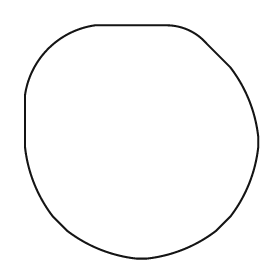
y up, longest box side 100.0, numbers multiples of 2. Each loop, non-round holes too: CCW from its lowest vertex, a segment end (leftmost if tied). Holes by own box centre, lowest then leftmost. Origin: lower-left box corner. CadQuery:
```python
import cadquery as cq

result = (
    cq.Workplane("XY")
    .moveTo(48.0, 0.0)
    .lineTo(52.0, 0.0)
    .threePointArc((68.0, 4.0), (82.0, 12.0))
    .lineTo(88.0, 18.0)
    .threePointArc((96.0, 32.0), (100.0, 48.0))
    .lineTo(100.0, 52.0)
    .threePointArc((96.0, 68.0), (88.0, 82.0))
    .lineTo(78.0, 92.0)
    .threePointArc((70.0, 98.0), (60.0, 100.0))
    .lineTo(30.0, 100.0)
    .threePointArc((10.0, 90.0), (0.0, 70.0))
    .lineTo(0.0, 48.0)
    .threePointArc((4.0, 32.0), (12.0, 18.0))
    .lineTo(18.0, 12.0)
    .threePointArc((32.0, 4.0), (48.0, 0.0))
    .close()
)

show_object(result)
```